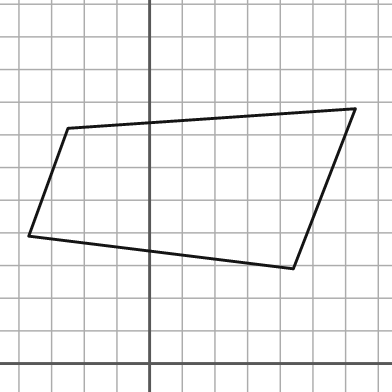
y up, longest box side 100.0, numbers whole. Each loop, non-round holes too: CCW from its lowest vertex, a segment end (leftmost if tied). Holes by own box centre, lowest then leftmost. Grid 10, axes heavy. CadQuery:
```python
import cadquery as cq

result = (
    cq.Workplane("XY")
    .moveTo(44.0, 29.0)
    .lineTo(63.0, 78.0)
    .lineTo(-25.0, 72.0)
    .lineTo(-37.0, 39.0)
    .close()
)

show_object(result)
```